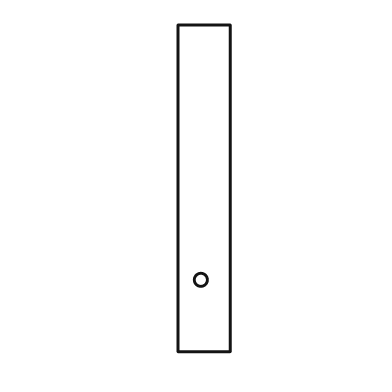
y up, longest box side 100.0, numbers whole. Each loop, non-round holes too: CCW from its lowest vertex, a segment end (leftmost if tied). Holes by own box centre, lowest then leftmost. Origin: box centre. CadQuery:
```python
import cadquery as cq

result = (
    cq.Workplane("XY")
    .moveTo(-8.0, -50.0)
    .lineTo(8.0, -50.0)
    .lineTo(8.0, 50.0)
    .lineTo(-8.0, 50.0)
    .close()
    .moveTo(-1.0, -28.0)
    .circle(2.0)
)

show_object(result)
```